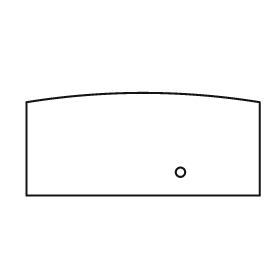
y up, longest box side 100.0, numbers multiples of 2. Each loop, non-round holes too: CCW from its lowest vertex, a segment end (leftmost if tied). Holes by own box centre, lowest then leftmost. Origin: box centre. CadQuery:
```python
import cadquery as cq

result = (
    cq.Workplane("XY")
    .moveTo(-50.0, -22.0)
    .lineTo(50.0, -22.0)
    .lineTo(50.0, 18.0)
    .threePointArc((0.0, 22.0), (-50.0, 18.0))
    .close()
    .moveTo(16.0, -12.0)
    .circle(2.0)
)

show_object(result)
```